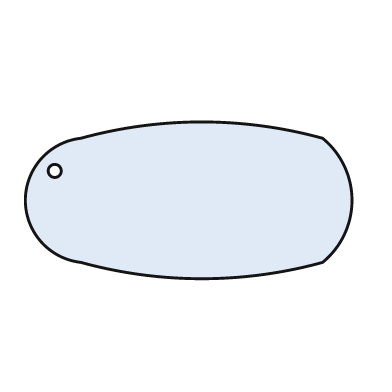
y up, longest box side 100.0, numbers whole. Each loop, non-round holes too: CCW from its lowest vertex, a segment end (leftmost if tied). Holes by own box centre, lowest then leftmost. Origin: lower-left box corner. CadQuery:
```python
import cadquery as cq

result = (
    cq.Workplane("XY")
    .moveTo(17.0, 5.0)
    .threePointArc((54.0, 0.0), (91.0, 5.0))
    .threePointArc((100.0, 24.0), (91.0, 43.0))
    .threePointArc((54.0, 48.0), (17.0, 43.0))
    .threePointArc((0.0, 24.0), (17.0, 5.0))
    .close()
    .moveTo(9.0, 33.0)
    .circle(2.0)
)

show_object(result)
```